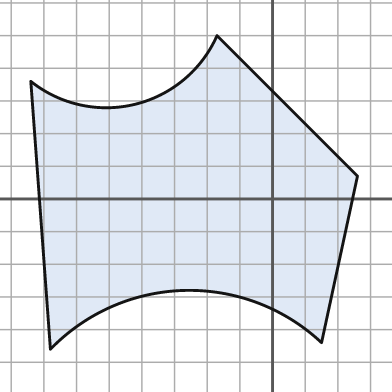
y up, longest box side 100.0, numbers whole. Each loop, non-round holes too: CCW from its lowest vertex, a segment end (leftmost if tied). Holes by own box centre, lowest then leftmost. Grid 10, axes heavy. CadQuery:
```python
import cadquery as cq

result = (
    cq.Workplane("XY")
    .moveTo(-68.0, -46.0)
    .threePointArc((-27.0, -28.0), (15.0, -44.0))
    .lineTo(26.0, 7.0)
    .lineTo(-17.0, 50.0)
    .threePointArc((-42.0, 29.0), (-74.0, 36.0))
    .close()
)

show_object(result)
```